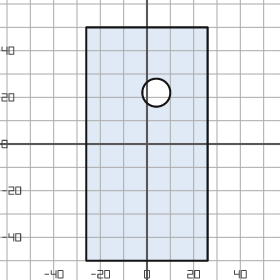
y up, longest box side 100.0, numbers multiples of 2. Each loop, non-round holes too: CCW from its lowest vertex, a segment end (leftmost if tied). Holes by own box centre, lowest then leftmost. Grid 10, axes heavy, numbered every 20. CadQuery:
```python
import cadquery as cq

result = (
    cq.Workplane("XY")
    .moveTo(-26.0, -50.0)
    .lineTo(26.0, -50.0)
    .lineTo(26.0, 50.0)
    .lineTo(-26.0, 50.0)
    .close()
    .moveTo(4.0, 22.0)
    .circle(6.0)
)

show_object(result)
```